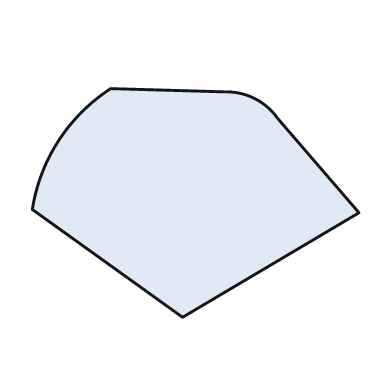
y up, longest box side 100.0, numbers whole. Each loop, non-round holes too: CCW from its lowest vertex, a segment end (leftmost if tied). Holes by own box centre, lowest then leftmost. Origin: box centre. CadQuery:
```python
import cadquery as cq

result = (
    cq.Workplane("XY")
    .moveTo(-4.0, -35.0)
    .lineTo(50.0, -3.0)
    .lineTo(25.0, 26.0)
    .threePointArc((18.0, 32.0), (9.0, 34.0))
    .lineTo(-26.0, 35.0)
    .threePointArc((-42.0, 19.0), (-50.0, -2.0))
    .close()
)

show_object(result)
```